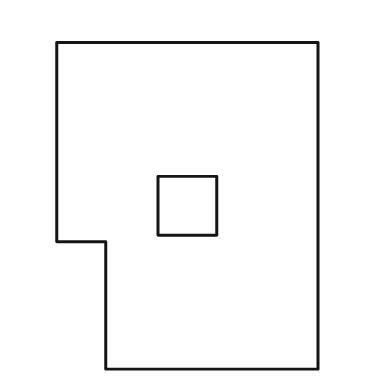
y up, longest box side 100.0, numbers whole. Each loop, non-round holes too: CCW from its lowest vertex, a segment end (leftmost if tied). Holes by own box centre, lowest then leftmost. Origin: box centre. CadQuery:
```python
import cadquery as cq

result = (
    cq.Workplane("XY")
    .moveTo(-25.0, -50.0)
    .lineTo(40.0, -50.0)
    .lineTo(40.0, 50.0)
    .lineTo(-40.0, 50.0)
    .lineTo(-40.0, -11.0)
    .lineTo(-25.0, -11.0)
    .close()
    .moveTo(-9.0, -9.0)
    .lineTo(9.0, -9.0)
    .lineTo(9.0, 9.0)
    .lineTo(-9.0, 9.0)
    .close()
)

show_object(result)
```